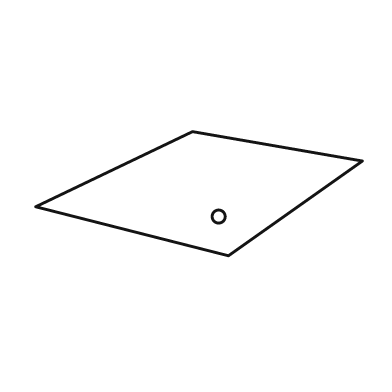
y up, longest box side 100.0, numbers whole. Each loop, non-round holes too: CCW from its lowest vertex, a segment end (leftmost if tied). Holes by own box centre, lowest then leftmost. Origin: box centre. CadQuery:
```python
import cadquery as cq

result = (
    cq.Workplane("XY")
    .moveTo(9.0, -19.0)
    .lineTo(50.0, 10.0)
    .lineTo(-2.0, 19.0)
    .lineTo(-50.0, -4.0)
    .close()
    .moveTo(6.0, -7.0)
    .circle(2.0)
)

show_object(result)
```